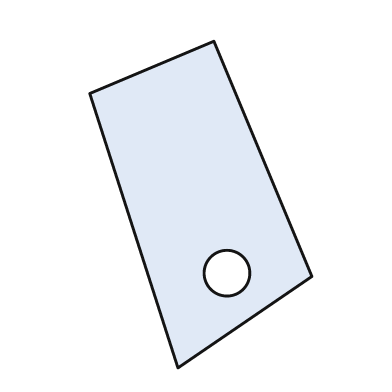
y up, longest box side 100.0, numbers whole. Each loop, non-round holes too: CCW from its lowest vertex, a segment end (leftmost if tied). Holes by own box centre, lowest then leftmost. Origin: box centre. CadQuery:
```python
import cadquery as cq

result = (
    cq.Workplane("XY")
    .moveTo(-7.0, -50.0)
    .lineTo(34.0, -22.0)
    .lineTo(4.0, 50.0)
    .lineTo(-34.0, 34.0)
    .close()
    .moveTo(8.0, -21.0)
    .circle(7.0)
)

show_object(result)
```